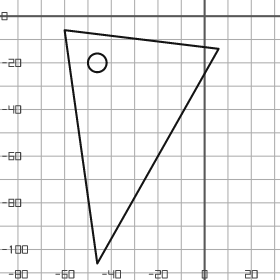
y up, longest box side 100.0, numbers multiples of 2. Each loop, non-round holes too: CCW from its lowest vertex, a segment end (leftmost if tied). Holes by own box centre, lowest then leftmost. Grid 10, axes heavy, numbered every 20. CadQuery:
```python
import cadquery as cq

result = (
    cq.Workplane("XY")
    .moveTo(-46.0, -106.0)
    .lineTo(6.0, -14.0)
    .lineTo(-60.0, -6.0)
    .close()
    .moveTo(-46.0, -20.0)
    .circle(4.0)
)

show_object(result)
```